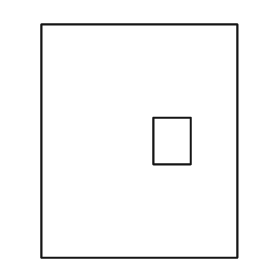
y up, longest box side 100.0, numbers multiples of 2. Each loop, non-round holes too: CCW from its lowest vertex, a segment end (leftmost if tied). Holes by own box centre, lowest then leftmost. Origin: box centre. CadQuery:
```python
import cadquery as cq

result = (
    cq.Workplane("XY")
    .moveTo(-42.0, -50.0)
    .lineTo(42.0, -50.0)
    .lineTo(42.0, 50.0)
    .lineTo(-42.0, 50.0)
    .close()
    .moveTo(6.0, -10.0)
    .lineTo(22.0, -10.0)
    .lineTo(22.0, 10.0)
    .lineTo(6.0, 10.0)
    .close()
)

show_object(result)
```